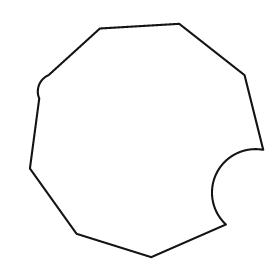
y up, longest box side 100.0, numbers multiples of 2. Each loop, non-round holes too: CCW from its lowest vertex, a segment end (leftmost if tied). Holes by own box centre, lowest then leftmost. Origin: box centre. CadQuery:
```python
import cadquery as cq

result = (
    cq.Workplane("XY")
    .moveTo(2.0, -50.0)
    .lineTo(34.0, -36.0)
    .threePointArc((30.0, -14.0), (50.0, -4.0))
    .lineTo(42.0, 28.0)
    .lineTo(14.0, 50.0)
    .lineTo(-20.0, 48.0)
    .lineTo(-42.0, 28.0)
    .threePointArc((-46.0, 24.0), (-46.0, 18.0))
    .lineTo(-50.0, -12.0)
    .lineTo(-30.0, -40.0)
    .close()
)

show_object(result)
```